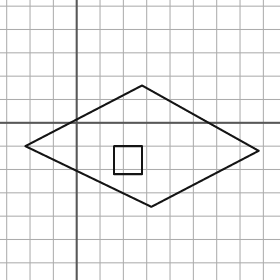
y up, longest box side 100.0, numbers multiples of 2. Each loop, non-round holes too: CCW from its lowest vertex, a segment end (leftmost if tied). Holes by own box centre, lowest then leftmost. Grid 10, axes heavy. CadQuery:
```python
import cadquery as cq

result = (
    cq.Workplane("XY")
    .moveTo(32.0, -36.0)
    .lineTo(78.0, -12.0)
    .lineTo(28.0, 16.0)
    .lineTo(-22.0, -10.0)
    .close()
    .moveTo(16.0, -22.0)
    .lineTo(28.0, -22.0)
    .lineTo(28.0, -10.0)
    .lineTo(16.0, -10.0)
    .close()
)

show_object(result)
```